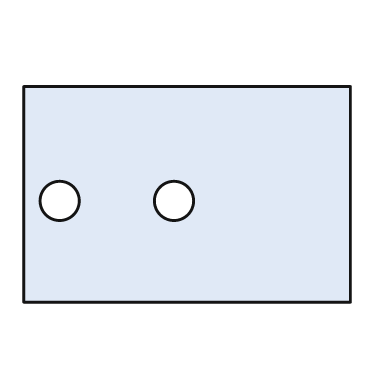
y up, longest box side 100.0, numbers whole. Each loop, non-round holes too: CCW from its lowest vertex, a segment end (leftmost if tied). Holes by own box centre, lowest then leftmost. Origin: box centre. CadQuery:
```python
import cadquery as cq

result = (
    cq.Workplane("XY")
    .moveTo(-50.0, -33.0)
    .lineTo(50.0, -33.0)
    .lineTo(50.0, 33.0)
    .lineTo(-50.0, 33.0)
    .close()
    .moveTo(-39.0, -2.0)
    .circle(6.0)
    .moveTo(-4.0, -2.0)
    .circle(6.0)
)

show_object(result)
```